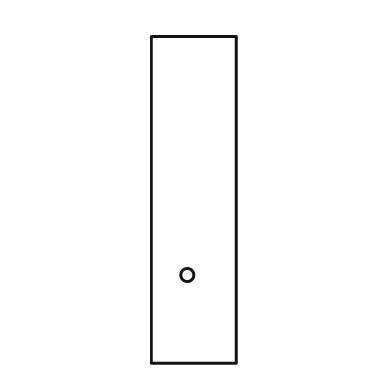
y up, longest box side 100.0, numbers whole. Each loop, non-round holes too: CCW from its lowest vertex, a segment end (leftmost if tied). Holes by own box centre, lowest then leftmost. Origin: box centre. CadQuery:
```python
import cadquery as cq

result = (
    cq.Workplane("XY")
    .moveTo(-13.0, -50.0)
    .lineTo(13.0, -50.0)
    .lineTo(13.0, 50.0)
    .lineTo(-13.0, 50.0)
    .close()
    .moveTo(-2.0, -23.0)
    .circle(2.0)
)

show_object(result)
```